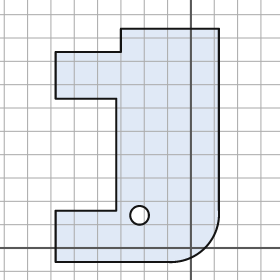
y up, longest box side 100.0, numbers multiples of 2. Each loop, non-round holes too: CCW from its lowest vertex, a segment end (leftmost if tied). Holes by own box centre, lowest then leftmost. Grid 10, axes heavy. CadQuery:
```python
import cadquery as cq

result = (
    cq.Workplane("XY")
    .moveTo(-58.0, -6.0)
    .lineTo(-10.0, -6.0)
    .threePointArc((6.0, 0.0), (12.0, 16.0))
    .lineTo(12.0, 94.0)
    .lineTo(-30.0, 94.0)
    .lineTo(-30.0, 84.0)
    .lineTo(-58.0, 84.0)
    .lineTo(-58.0, 64.0)
    .lineTo(-32.0, 64.0)
    .lineTo(-32.0, 16.0)
    .lineTo(-58.0, 16.0)
    .close()
    .moveTo(-22.0, 14.0)
    .circle(4.0)
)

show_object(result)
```